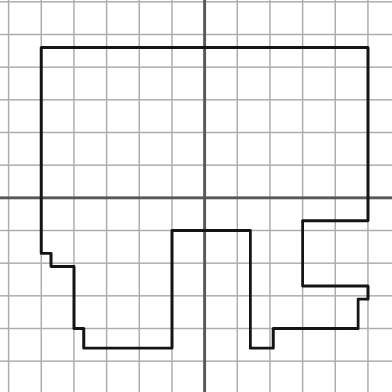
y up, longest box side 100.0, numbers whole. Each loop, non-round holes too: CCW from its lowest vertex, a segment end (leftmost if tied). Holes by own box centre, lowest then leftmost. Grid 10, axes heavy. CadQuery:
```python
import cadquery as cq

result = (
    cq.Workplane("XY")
    .moveTo(-37.0, -46.0)
    .lineTo(-10.0, -46.0)
    .lineTo(-10.0, -10.0)
    .lineTo(14.0, -10.0)
    .lineTo(14.0, -46.0)
    .lineTo(21.0, -46.0)
    .lineTo(21.0, -40.0)
    .lineTo(47.0, -40.0)
    .lineTo(47.0, -31.0)
    .lineTo(50.0, -31.0)
    .lineTo(50.0, -27.0)
    .lineTo(30.0, -27.0)
    .lineTo(30.0, -7.0)
    .lineTo(50.0, -7.0)
    .lineTo(50.0, 46.0)
    .lineTo(-50.0, 46.0)
    .lineTo(-50.0, -17.0)
    .lineTo(-47.0, -17.0)
    .lineTo(-47.0, -21.0)
    .lineTo(-40.0, -21.0)
    .lineTo(-40.0, -40.0)
    .lineTo(-37.0, -40.0)
    .close()
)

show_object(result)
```